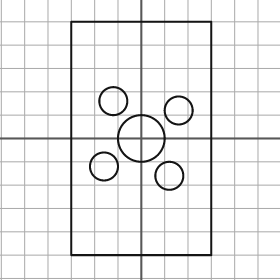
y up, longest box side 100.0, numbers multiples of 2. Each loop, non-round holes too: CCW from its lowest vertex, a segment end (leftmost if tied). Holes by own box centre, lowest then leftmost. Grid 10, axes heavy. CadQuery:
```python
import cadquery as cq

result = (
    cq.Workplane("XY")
    .moveTo(-30.0, -50.0)
    .lineTo(30.0, -50.0)
    .lineTo(30.0, 50.0)
    .lineTo(-30.0, 50.0)
    .close()
    .moveTo(12.0, -16.0)
    .circle(6.0)
    .moveTo(-16.0, -12.0)
    .circle(6.0)
    .moveTo(0.0, 0.0)
    .circle(10.0)
    .moveTo(16.0, 12.0)
    .circle(6.0)
    .moveTo(-12.0, 16.0)
    .circle(6.0)
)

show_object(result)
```